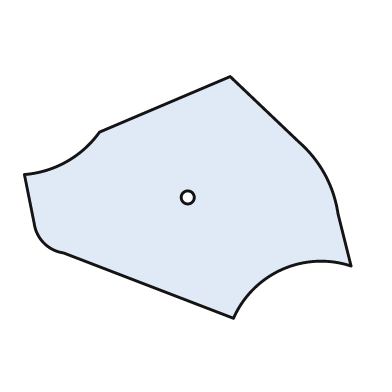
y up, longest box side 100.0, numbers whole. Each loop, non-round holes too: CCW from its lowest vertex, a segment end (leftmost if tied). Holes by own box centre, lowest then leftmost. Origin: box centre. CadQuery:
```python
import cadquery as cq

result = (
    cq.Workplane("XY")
    .moveTo(14.0, -37.0)
    .threePointArc((29.0, -22.0), (50.0, -21.0))
    .lineTo(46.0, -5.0)
    .threePointArc((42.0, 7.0), (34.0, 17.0))
    .lineTo(13.0, 37.0)
    .lineTo(-27.0, 20.0)
    .threePointArc((-37.0, 11.0), (-50.0, 7.0))
    .lineTo(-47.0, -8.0)
    .threePointArc((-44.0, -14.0), (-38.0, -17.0))
    .close()
    .moveTo(0.0, 0.0)
    .circle(2.0)
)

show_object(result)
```